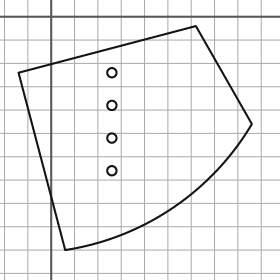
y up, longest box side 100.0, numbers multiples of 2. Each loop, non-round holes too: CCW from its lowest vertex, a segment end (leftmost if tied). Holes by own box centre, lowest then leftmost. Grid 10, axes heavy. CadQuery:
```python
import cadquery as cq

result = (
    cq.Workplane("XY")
    .moveTo(6.0, -100.0)
    .threePointArc((52.0, -82.0), (86.0, -46.0))
    .lineTo(62.0, -4.0)
    .lineTo(-14.0, -24.0)
    .close()
    .moveTo(26.0, -66.0)
    .circle(2.0)
    .moveTo(26.0, -52.0)
    .circle(2.0)
    .moveTo(26.0, -38.0)
    .circle(2.0)
    .moveTo(26.0, -24.0)
    .circle(2.0)
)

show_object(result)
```